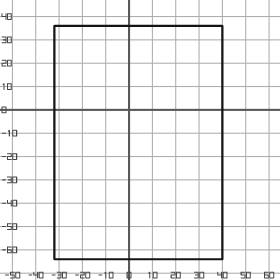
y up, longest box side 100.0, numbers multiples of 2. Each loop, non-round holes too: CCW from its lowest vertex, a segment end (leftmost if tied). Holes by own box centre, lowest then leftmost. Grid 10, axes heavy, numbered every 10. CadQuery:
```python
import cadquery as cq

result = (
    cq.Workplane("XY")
    .moveTo(-32.0, -64.0)
    .lineTo(40.0, -64.0)
    .lineTo(40.0, 36.0)
    .lineTo(-32.0, 36.0)
    .close()
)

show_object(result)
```